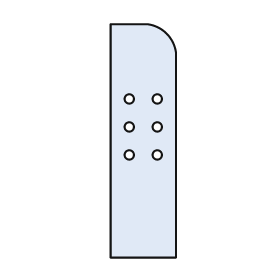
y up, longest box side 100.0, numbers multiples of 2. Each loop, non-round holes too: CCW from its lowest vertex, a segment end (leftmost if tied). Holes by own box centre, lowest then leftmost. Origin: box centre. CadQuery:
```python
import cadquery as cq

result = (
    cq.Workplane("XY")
    .moveTo(-14.0, -50.0)
    .lineTo(14.0, -50.0)
    .lineTo(14.0, 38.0)
    .threePointArc((10.0, 46.0), (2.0, 50.0))
    .lineTo(-14.0, 50.0)
    .close()
    .moveTo(-6.0, -6.0)
    .circle(2.0)
    .moveTo(6.0, -6.0)
    .circle(2.0)
    .moveTo(-6.0, 6.0)
    .circle(2.0)
    .moveTo(6.0, 6.0)
    .circle(2.0)
    .moveTo(-6.0, 18.0)
    .circle(2.0)
    .moveTo(6.0, 18.0)
    .circle(2.0)
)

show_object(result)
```